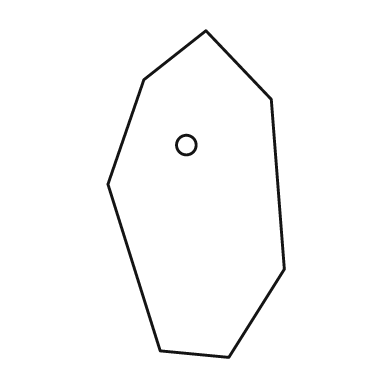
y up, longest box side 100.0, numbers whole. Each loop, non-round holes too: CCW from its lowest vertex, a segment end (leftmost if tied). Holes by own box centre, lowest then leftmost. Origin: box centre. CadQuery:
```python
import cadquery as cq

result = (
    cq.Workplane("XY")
    .moveTo(10.0, -50.0)
    .lineTo(27.0, -23.0)
    .lineTo(23.0, 29.0)
    .lineTo(3.0, 50.0)
    .lineTo(-16.0, 35.0)
    .lineTo(-27.0, 3.0)
    .lineTo(-11.0, -48.0)
    .close()
    .moveTo(-3.0, 15.0)
    .circle(3.0)
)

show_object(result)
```